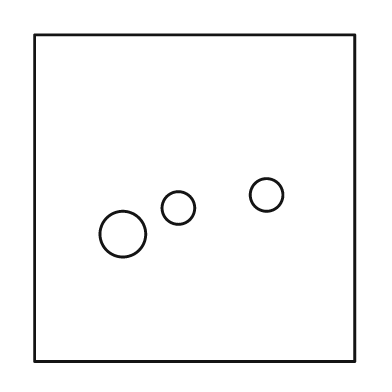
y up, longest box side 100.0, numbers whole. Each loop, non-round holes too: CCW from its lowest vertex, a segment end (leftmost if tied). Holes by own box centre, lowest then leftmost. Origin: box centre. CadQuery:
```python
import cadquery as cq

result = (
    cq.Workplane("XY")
    .moveTo(-49.0, -50.0)
    .lineTo(49.0, -50.0)
    .lineTo(49.0, 50.0)
    .lineTo(-49.0, 50.0)
    .close()
    .moveTo(-22.0, -11.0)
    .circle(7.0)
    .moveTo(-5.0, -3.0)
    .circle(5.0)
    .moveTo(22.0, 1.0)
    .circle(5.0)
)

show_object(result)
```